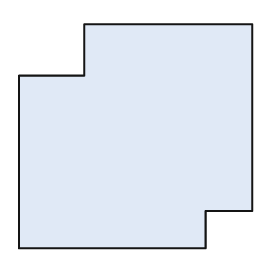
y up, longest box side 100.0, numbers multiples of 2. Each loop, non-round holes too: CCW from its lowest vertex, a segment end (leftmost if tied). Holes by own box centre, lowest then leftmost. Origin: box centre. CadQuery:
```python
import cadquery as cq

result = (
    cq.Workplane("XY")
    .moveTo(-50.0, -48.0)
    .lineTo(30.0, -48.0)
    .lineTo(30.0, -32.0)
    .lineTo(50.0, -32.0)
    .lineTo(50.0, 48.0)
    .lineTo(-22.0, 48.0)
    .lineTo(-22.0, 26.0)
    .lineTo(-50.0, 26.0)
    .close()
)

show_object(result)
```